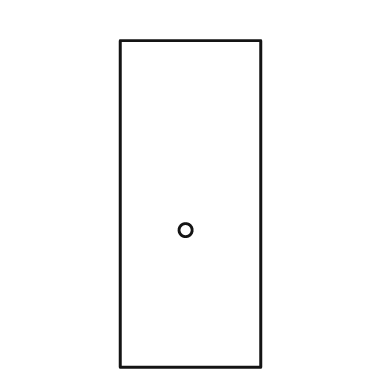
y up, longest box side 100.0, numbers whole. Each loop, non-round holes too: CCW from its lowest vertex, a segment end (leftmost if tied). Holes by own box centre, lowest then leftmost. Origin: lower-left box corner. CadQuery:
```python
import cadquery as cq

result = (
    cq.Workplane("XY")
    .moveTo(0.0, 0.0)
    .lineTo(43.0, 0.0)
    .lineTo(43.0, 100.0)
    .lineTo(0.0, 100.0)
    .close()
    .moveTo(20.0, 42.0)
    .circle(2.0)
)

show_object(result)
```